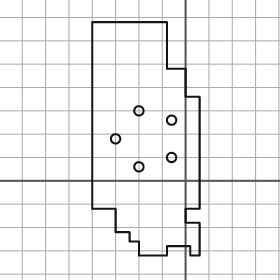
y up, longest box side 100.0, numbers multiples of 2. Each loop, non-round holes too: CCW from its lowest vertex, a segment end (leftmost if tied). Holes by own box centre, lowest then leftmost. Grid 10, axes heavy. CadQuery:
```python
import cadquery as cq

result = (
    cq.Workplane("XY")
    .moveTo(-20.0, -32.0)
    .lineTo(-8.0, -32.0)
    .lineTo(-8.0, -28.0)
    .lineTo(2.0, -28.0)
    .lineTo(2.0, -32.0)
    .lineTo(6.0, -32.0)
    .lineTo(6.0, -18.0)
    .lineTo(0.0, -18.0)
    .lineTo(0.0, -12.0)
    .lineTo(6.0, -12.0)
    .lineTo(6.0, 36.0)
    .lineTo(0.0, 36.0)
    .lineTo(0.0, 48.0)
    .lineTo(-8.0, 48.0)
    .lineTo(-8.0, 68.0)
    .lineTo(-40.0, 68.0)
    .lineTo(-40.0, -12.0)
    .lineTo(-30.0, -12.0)
    .lineTo(-30.0, -22.0)
    .lineTo(-24.0, -22.0)
    .lineTo(-24.0, -26.0)
    .lineTo(-20.0, -26.0)
    .close()
    .moveTo(-20.0, 6.0)
    .circle(2.0)
    .moveTo(-6.0, 10.0)
    .circle(2.0)
    .moveTo(-30.0, 18.0)
    .circle(2.0)
    .moveTo(-6.0, 26.0)
    .circle(2.0)
    .moveTo(-20.0, 30.0)
    .circle(2.0)
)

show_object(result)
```